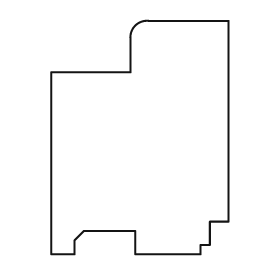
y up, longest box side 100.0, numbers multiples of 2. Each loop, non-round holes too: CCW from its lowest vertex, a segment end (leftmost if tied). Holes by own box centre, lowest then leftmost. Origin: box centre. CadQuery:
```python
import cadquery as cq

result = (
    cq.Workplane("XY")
    .moveTo(-38.0, -50.0)
    .lineTo(-28.0, -50.0)
    .lineTo(-28.0, -44.0)
    .lineTo(-24.0, -40.0)
    .lineTo(-2.0, -40.0)
    .lineTo(-2.0, -50.0)
    .lineTo(26.0, -50.0)
    .lineTo(26.0, -46.0)
    .lineTo(30.0, -46.0)
    .lineTo(30.0, -36.0)
    .lineTo(38.0, -36.0)
    .lineTo(38.0, 50.0)
    .lineTo(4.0, 50.0)
    .threePointArc((-2.0, 48.0), (-4.0, 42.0))
    .lineTo(-4.0, 28.0)
    .lineTo(-38.0, 28.0)
    .close()
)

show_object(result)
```